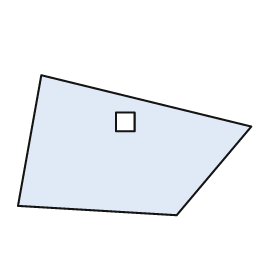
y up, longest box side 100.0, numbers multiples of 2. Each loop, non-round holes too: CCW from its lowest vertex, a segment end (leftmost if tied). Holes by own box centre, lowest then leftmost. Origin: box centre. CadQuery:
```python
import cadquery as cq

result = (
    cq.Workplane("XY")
    .moveTo(18.0, -30.0)
    .lineTo(50.0, 8.0)
    .lineTo(-40.0, 30.0)
    .lineTo(-50.0, -26.0)
    .close()
    .moveTo(-8.0, 6.0)
    .lineTo(0.0, 6.0)
    .lineTo(0.0, 14.0)
    .lineTo(-8.0, 14.0)
    .close()
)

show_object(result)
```